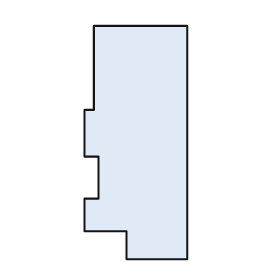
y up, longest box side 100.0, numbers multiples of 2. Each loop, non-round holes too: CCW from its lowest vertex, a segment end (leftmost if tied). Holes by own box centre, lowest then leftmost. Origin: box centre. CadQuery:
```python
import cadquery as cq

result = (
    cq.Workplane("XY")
    .moveTo(-4.0, -50.0)
    .lineTo(22.0, -50.0)
    .lineTo(22.0, 50.0)
    .lineTo(-18.0, 50.0)
    .lineTo(-18.0, 14.0)
    .lineTo(-22.0, 14.0)
    .lineTo(-22.0, -6.0)
    .lineTo(-16.0, -6.0)
    .lineTo(-16.0, -24.0)
    .lineTo(-22.0, -24.0)
    .lineTo(-22.0, -38.0)
    .lineTo(-4.0, -38.0)
    .close()
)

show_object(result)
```